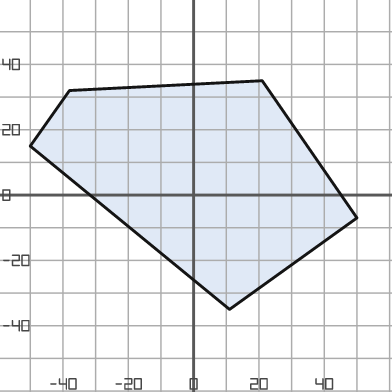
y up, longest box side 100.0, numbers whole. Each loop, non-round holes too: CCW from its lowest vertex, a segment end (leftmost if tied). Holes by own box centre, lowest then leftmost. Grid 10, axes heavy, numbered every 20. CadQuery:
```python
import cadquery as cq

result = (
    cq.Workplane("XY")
    .moveTo(11.0, -35.0)
    .lineTo(50.0, -7.0)
    .lineTo(21.0, 35.0)
    .lineTo(-38.0, 32.0)
    .lineTo(-50.0, 15.0)
    .close()
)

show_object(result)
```